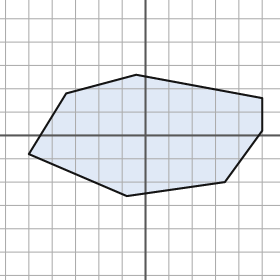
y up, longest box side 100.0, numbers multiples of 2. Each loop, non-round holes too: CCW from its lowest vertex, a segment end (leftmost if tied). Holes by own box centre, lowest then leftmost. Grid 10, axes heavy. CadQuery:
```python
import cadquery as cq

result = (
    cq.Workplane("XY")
    .moveTo(-8.0, -26.0)
    .lineTo(34.0, -20.0)
    .lineTo(50.0, 2.0)
    .lineTo(50.0, 16.0)
    .lineTo(-4.0, 26.0)
    .lineTo(-34.0, 18.0)
    .lineTo(-50.0, -8.0)
    .close()
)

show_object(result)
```